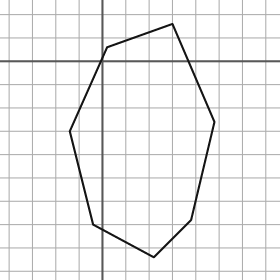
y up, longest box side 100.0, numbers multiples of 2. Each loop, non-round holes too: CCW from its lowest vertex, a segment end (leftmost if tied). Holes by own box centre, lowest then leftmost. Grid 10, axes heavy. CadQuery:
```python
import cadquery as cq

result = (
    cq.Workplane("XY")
    .moveTo(22.0, -84.0)
    .lineTo(38.0, -68.0)
    .lineTo(48.0, -26.0)
    .lineTo(30.0, 16.0)
    .lineTo(2.0, 6.0)
    .lineTo(-14.0, -30.0)
    .lineTo(-4.0, -70.0)
    .close()
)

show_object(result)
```